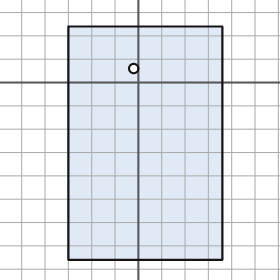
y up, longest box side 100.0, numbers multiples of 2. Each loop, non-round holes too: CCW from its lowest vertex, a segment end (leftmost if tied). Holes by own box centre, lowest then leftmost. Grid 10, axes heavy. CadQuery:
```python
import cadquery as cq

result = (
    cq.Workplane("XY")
    .moveTo(-30.0, -76.0)
    .lineTo(36.0, -76.0)
    .lineTo(36.0, 24.0)
    .lineTo(-30.0, 24.0)
    .close()
    .moveTo(-2.0, 6.0)
    .circle(2.0)
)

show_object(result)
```